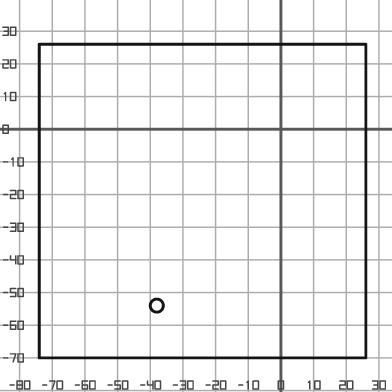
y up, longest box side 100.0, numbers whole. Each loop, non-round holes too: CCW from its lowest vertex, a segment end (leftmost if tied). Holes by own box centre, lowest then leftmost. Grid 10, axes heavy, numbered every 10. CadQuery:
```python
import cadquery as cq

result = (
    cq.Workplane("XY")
    .moveTo(-74.0, -70.0)
    .lineTo(26.0, -70.0)
    .lineTo(26.0, 26.0)
    .lineTo(-74.0, 26.0)
    .close()
    .moveTo(-38.0, -54.0)
    .circle(2.0)
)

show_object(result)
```